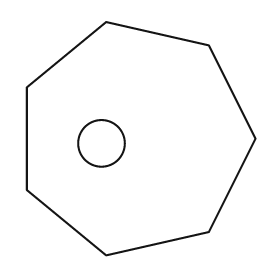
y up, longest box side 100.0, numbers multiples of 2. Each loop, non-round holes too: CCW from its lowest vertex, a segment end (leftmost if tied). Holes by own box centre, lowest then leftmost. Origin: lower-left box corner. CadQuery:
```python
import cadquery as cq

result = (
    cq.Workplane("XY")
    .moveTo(34.0, 0.0)
    .lineTo(78.0, 10.0)
    .lineTo(98.0, 50.0)
    .lineTo(78.0, 90.0)
    .lineTo(34.0, 100.0)
    .lineTo(0.0, 72.0)
    .lineTo(0.0, 28.0)
    .close()
    .moveTo(32.0, 48.0)
    .circle(10.0)
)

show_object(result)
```